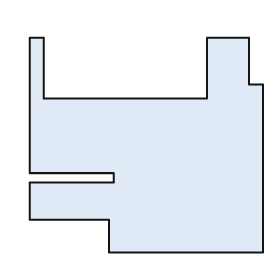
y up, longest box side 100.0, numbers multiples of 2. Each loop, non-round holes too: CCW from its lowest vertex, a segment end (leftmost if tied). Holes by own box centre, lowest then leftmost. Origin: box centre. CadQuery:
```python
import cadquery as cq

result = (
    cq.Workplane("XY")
    .moveTo(-16.0, -46.0)
    .lineTo(50.0, -46.0)
    .lineTo(50.0, 26.0)
    .lineTo(44.0, 26.0)
    .lineTo(44.0, 46.0)
    .lineTo(26.0, 46.0)
    .lineTo(26.0, 20.0)
    .lineTo(-44.0, 20.0)
    .lineTo(-44.0, 46.0)
    .lineTo(-50.0, 46.0)
    .lineTo(-50.0, -12.0)
    .lineTo(-14.0, -12.0)
    .lineTo(-14.0, -16.0)
    .lineTo(-50.0, -16.0)
    .lineTo(-50.0, -32.0)
    .lineTo(-16.0, -32.0)
    .close()
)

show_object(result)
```